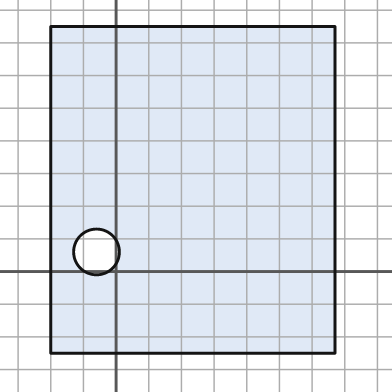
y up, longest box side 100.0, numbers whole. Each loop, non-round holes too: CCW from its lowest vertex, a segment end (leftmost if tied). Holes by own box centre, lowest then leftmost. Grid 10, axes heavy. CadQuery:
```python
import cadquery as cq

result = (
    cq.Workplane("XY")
    .moveTo(-20.0, -25.0)
    .lineTo(67.0, -25.0)
    .lineTo(67.0, 75.0)
    .lineTo(-20.0, 75.0)
    .close()
    .moveTo(-6.0, 6.0)
    .circle(7.0)
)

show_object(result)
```